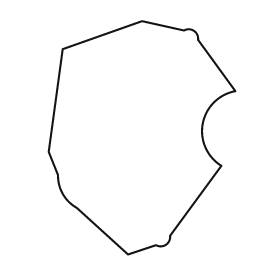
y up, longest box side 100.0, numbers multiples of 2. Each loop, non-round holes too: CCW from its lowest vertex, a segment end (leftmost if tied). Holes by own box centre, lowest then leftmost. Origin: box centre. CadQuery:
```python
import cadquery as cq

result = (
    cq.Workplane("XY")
    .moveTo(-6.0, -50.0)
    .lineTo(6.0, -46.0)
    .threePointArc((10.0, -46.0), (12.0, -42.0))
    .lineTo(34.0, -12.0)
    .threePointArc((26.0, 6.0), (40.0, 20.0))
    .lineTo(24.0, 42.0)
    .threePointArc((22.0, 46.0), (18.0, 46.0))
    .lineTo(0.0, 50.0)
    .lineTo(-34.0, 38.0)
    .lineTo(-40.0, -6.0)
    .lineTo(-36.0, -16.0)
    .threePointArc((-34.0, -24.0), (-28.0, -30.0))
    .close()
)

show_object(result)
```